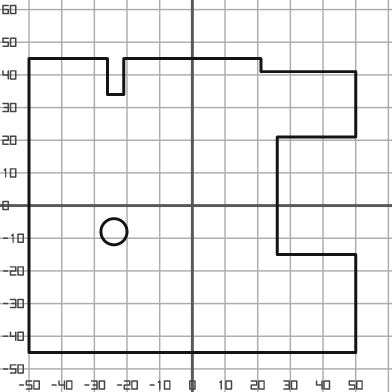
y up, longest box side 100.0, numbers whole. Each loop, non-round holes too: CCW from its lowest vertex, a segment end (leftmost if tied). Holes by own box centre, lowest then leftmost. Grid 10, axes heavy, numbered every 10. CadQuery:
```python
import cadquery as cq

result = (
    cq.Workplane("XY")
    .moveTo(-50.0, -45.0)
    .lineTo(50.0, -45.0)
    .lineTo(50.0, -15.0)
    .lineTo(26.0, -15.0)
    .lineTo(26.0, 21.0)
    .lineTo(50.0, 21.0)
    .lineTo(50.0, 41.0)
    .lineTo(21.0, 41.0)
    .lineTo(21.0, 45.0)
    .lineTo(-21.0, 45.0)
    .lineTo(-21.0, 34.0)
    .lineTo(-26.0, 34.0)
    .lineTo(-26.0, 45.0)
    .lineTo(-50.0, 45.0)
    .close()
    .moveTo(-24.0, -8.0)
    .circle(4.0)
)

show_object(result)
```